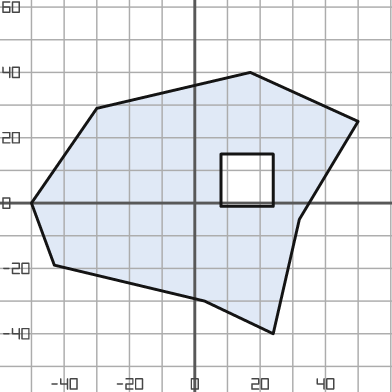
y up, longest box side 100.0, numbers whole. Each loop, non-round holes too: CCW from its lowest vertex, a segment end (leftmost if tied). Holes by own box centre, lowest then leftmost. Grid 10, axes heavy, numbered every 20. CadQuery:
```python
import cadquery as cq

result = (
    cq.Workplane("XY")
    .moveTo(24.0, -40.0)
    .lineTo(32.0, -5.0)
    .lineTo(50.0, 25.0)
    .lineTo(17.0, 40.0)
    .lineTo(-30.0, 29.0)
    .lineTo(-50.0, 0.0)
    .lineTo(-43.0, -19.0)
    .lineTo(3.0, -30.0)
    .close()
    .moveTo(8.0, -1.0)
    .lineTo(24.0, -1.0)
    .lineTo(24.0, 15.0)
    .lineTo(8.0, 15.0)
    .close()
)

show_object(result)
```